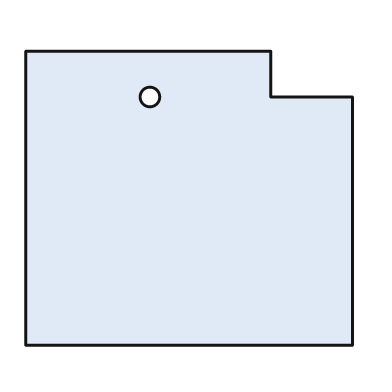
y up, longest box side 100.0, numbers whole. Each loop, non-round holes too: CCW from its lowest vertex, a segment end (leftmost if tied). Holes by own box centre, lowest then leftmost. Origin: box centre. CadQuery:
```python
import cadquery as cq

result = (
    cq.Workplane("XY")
    .moveTo(-50.0, -45.0)
    .lineTo(50.0, -45.0)
    .lineTo(50.0, 31.0)
    .lineTo(25.0, 31.0)
    .lineTo(25.0, 45.0)
    .lineTo(-50.0, 45.0)
    .close()
    .moveTo(-12.0, 31.0)
    .circle(3.0)
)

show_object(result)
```